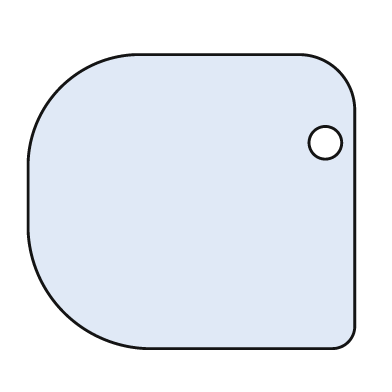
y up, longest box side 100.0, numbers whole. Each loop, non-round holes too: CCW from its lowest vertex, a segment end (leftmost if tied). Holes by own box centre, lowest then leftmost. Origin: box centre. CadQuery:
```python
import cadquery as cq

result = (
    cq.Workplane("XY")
    .moveTo(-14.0, -45.0)
    .lineTo(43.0, -45.0)
    .threePointArc((48.0, -43.0), (50.0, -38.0))
    .lineTo(50.0, 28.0)
    .threePointArc((45.0, 40.0), (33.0, 45.0))
    .lineTo(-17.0, 45.0)
    .threePointArc((-40.0, 35.0), (-50.0, 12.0))
    .lineTo(-50.0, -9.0)
    .threePointArc((-39.0, -34.0), (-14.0, -45.0))
    .close()
    .moveTo(41.0, 18.0)
    .circle(5.0)
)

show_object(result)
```